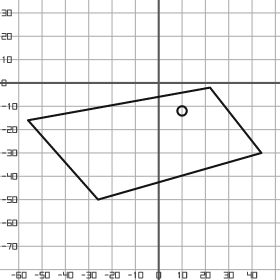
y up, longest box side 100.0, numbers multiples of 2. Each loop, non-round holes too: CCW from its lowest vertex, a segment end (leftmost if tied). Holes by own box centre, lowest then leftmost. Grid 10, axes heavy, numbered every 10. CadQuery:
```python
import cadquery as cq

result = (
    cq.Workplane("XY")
    .moveTo(-26.0, -50.0)
    .lineTo(44.0, -30.0)
    .lineTo(22.0, -2.0)
    .lineTo(-56.0, -16.0)
    .close()
    .moveTo(10.0, -12.0)
    .circle(2.0)
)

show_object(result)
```